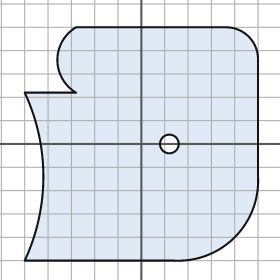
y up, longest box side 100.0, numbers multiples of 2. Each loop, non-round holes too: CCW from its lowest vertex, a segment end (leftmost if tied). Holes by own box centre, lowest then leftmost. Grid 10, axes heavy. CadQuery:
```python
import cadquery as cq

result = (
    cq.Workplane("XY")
    .moveTo(-50.0, -50.0)
    .lineTo(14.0, -50.0)
    .threePointArc((40.0, -40.0), (50.0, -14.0))
    .lineTo(50.0, 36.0)
    .threePointArc((46.0, 46.0), (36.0, 50.0))
    .lineTo(-28.0, 50.0)
    .threePointArc((-36.0, 36.0), (-28.0, 22.0))
    .lineTo(-50.0, 22.0)
    .threePointArc((-42.0, -14.0), (-50.0, -50.0))
    .close()
    .moveTo(12.0, 0.0)
    .circle(4.0)
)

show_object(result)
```